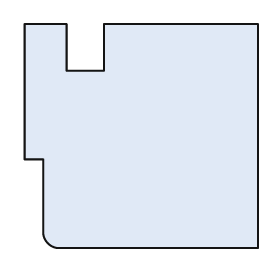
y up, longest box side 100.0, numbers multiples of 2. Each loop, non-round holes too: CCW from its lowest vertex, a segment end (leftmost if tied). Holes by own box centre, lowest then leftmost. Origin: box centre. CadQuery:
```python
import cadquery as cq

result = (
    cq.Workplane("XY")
    .moveTo(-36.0, -48.0)
    .lineTo(50.0, -48.0)
    .lineTo(50.0, 48.0)
    .lineTo(-16.0, 48.0)
    .lineTo(-16.0, 28.0)
    .lineTo(-32.0, 28.0)
    .lineTo(-32.0, 48.0)
    .lineTo(-50.0, 48.0)
    .lineTo(-50.0, -10.0)
    .lineTo(-42.0, -10.0)
    .lineTo(-42.0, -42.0)
    .threePointArc((-40.0, -46.0), (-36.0, -48.0))
    .close()
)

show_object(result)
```